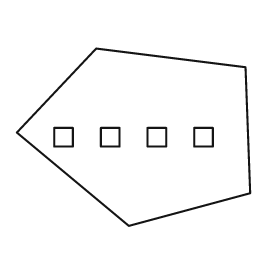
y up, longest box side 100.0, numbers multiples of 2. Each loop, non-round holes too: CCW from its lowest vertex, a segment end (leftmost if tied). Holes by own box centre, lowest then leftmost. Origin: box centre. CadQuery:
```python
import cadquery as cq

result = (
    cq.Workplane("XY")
    .moveTo(-2.0, -38.0)
    .lineTo(50.0, -24.0)
    .lineTo(48.0, 30.0)
    .lineTo(-16.0, 38.0)
    .lineTo(-50.0, 2.0)
    .close()
    .moveTo(-34.0, -4.0)
    .lineTo(-26.0, -4.0)
    .lineTo(-26.0, 4.0)
    .lineTo(-34.0, 4.0)
    .close()
    .moveTo(-14.0, -4.0)
    .lineTo(-6.0, -4.0)
    .lineTo(-6.0, 4.0)
    .lineTo(-14.0, 4.0)
    .close()
    .moveTo(6.0, -4.0)
    .lineTo(14.0, -4.0)
    .lineTo(14.0, 4.0)
    .lineTo(6.0, 4.0)
    .close()
    .moveTo(26.0, -4.0)
    .lineTo(34.0, -4.0)
    .lineTo(34.0, 4.0)
    .lineTo(26.0, 4.0)
    .close()
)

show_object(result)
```